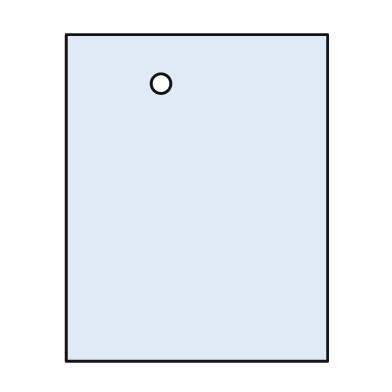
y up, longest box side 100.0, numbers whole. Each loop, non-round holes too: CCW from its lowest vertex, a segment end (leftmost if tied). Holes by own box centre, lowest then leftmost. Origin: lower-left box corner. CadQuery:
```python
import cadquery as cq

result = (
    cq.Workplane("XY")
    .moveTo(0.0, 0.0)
    .lineTo(80.0, 0.0)
    .lineTo(80.0, 100.0)
    .lineTo(0.0, 100.0)
    .close()
    .moveTo(29.0, 85.0)
    .circle(3.0)
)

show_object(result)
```